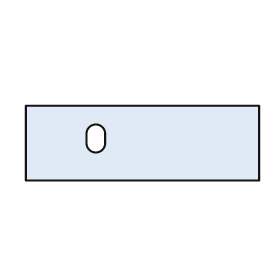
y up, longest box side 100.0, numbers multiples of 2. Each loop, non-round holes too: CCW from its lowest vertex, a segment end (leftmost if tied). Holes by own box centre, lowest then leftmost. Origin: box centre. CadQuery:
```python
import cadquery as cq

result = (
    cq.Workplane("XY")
    .moveTo(-50.0, -16.0)
    .lineTo(50.0, -16.0)
    .lineTo(50.0, 16.0)
    .lineTo(-50.0, 16.0)
    .close()
    .moveTo(-24.0, 0.0)
    .threePointArc((-20.0, -4.0), (-16.0, 0.0))
    .lineTo(-16.0, 4.0)
    .threePointArc((-20.0, 8.0), (-24.0, 4.0))
    .close()
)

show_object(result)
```